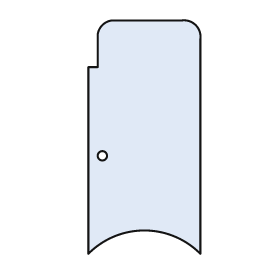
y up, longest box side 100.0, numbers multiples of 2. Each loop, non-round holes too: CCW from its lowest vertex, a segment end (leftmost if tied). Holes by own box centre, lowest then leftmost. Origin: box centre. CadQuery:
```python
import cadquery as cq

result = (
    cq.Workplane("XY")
    .moveTo(-24.0, -50.0)
    .threePointArc((0.0, -40.0), (24.0, -50.0))
    .lineTo(24.0, 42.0)
    .threePointArc((22.0, 48.0), (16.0, 50.0))
    .lineTo(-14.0, 50.0)
    .threePointArc((-18.0, 48.0), (-20.0, 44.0))
    .lineTo(-20.0, 30.0)
    .lineTo(-24.0, 30.0)
    .close()
    .moveTo(-18.0, -8.0)
    .circle(2.0)
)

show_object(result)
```